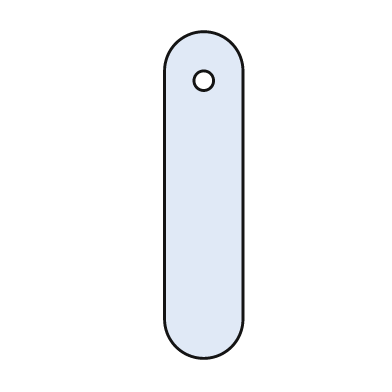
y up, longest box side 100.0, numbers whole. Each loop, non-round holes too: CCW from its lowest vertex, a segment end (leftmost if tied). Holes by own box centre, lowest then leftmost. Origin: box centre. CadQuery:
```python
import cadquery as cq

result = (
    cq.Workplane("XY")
    .moveTo(-12.0, -38.0)
    .threePointArc((0.0, -50.0), (12.0, -38.0))
    .lineTo(12.0, 38.0)
    .threePointArc((0.0, 50.0), (-12.0, 38.0))
    .close()
    .moveTo(0.0, 35.0)
    .circle(3.0)
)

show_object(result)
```